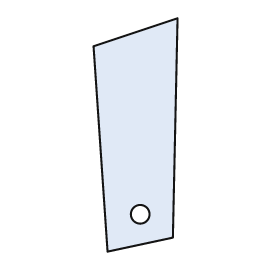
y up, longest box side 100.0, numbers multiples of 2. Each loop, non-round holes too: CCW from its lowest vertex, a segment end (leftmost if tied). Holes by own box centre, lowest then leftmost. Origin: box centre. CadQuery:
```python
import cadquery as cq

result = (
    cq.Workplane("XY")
    .moveTo(-12.0, -50.0)
    .lineTo(16.0, -44.0)
    .lineTo(18.0, 50.0)
    .lineTo(-18.0, 38.0)
    .close()
    .moveTo(2.0, -34.0)
    .circle(4.0)
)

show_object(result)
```